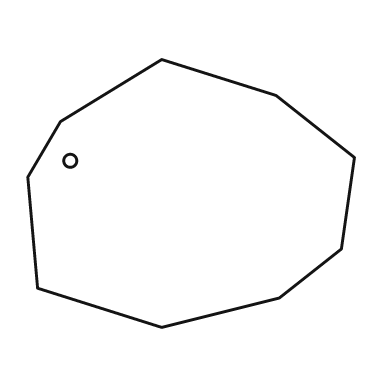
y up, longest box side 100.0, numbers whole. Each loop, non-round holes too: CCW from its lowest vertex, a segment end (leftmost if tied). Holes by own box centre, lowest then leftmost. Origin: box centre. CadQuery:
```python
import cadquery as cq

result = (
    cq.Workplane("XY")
    .moveTo(-9.0, -41.0)
    .lineTo(27.0, -32.0)
    .lineTo(46.0, -17.0)
    .lineTo(50.0, 11.0)
    .lineTo(26.0, 30.0)
    .lineTo(-9.0, 41.0)
    .lineTo(-40.0, 22.0)
    .lineTo(-50.0, 5.0)
    .lineTo(-47.0, -29.0)
    .close()
    .moveTo(-37.0, 10.0)
    .circle(2.0)
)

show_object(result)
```